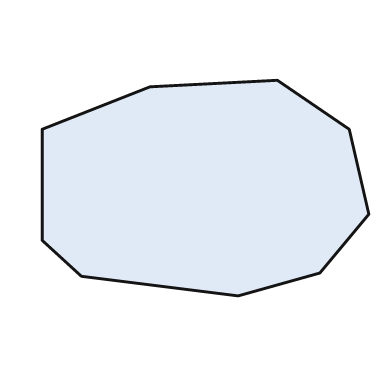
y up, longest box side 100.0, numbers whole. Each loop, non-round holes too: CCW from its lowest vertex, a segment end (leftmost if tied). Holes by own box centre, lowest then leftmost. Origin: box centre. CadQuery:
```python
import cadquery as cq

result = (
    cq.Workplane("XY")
    .moveTo(10.0, -33.0)
    .lineTo(35.0, -26.0)
    .lineTo(50.0, -8.0)
    .lineTo(44.0, 18.0)
    .lineTo(22.0, 33.0)
    .lineTo(-17.0, 31.0)
    .lineTo(-50.0, 18.0)
    .lineTo(-50.0, -16.0)
    .lineTo(-38.0, -27.0)
    .close()
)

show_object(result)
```